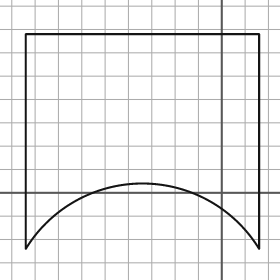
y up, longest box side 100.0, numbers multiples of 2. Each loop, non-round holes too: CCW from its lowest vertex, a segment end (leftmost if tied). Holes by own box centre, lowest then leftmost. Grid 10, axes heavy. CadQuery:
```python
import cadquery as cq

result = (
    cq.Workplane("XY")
    .moveTo(-84.0, -24.0)
    .threePointArc((-34.0, 4.0), (16.0, -24.0))
    .lineTo(16.0, 68.0)
    .lineTo(-84.0, 68.0)
    .close()
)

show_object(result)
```